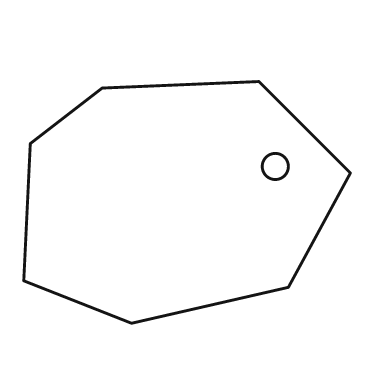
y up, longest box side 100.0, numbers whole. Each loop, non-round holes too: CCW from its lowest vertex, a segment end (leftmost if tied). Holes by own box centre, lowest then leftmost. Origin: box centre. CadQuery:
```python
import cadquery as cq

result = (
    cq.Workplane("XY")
    .moveTo(-17.0, -37.0)
    .lineTo(31.0, -26.0)
    .lineTo(50.0, 9.0)
    .lineTo(22.0, 37.0)
    .lineTo(-26.0, 35.0)
    .lineTo(-48.0, 18.0)
    .lineTo(-50.0, -24.0)
    .close()
    .moveTo(27.0, 11.0)
    .circle(4.0)
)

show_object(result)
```